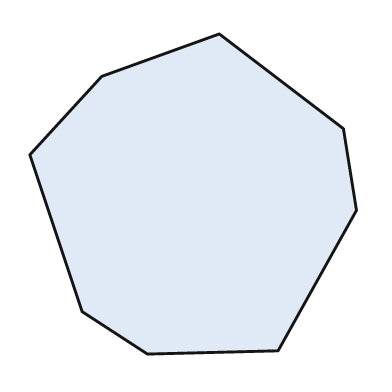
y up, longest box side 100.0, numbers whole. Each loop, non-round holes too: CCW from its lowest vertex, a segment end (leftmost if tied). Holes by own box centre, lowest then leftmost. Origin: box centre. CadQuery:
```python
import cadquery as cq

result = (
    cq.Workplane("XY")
    .moveTo(-14.0, -49.0)
    .lineTo(26.0, -48.0)
    .lineTo(50.0, -5.0)
    .lineTo(46.0, 20.0)
    .lineTo(8.0, 49.0)
    .lineTo(-28.0, 36.0)
    .lineTo(-50.0, 12.0)
    .lineTo(-34.0, -36.0)
    .close()
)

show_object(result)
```